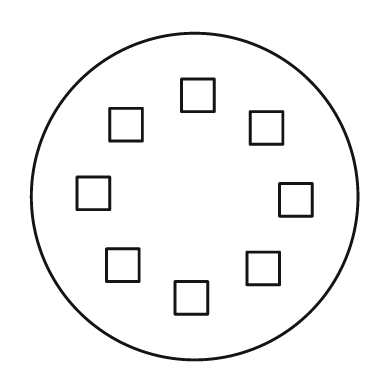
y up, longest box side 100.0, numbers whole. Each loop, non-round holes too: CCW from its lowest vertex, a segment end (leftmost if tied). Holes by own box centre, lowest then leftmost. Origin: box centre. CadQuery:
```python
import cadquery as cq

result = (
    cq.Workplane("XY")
    .moveTo(0.0, 0.0)
    .circle(50.0)
    .moveTo(-6.0, -36.0)
    .lineTo(4.0, -36.0)
    .lineTo(4.0, -26.0)
    .lineTo(-6.0, -26.0)
    .close()
    .moveTo(16.0, -27.0)
    .lineTo(26.0, -27.0)
    .lineTo(26.0, -17.0)
    .lineTo(16.0, -17.0)
    .close()
    .moveTo(-27.0, -26.0)
    .lineTo(-17.0, -26.0)
    .lineTo(-17.0, -16.0)
    .lineTo(-27.0, -16.0)
    .close()
    .moveTo(26.0, -6.0)
    .lineTo(36.0, -6.0)
    .lineTo(36.0, 4.0)
    .lineTo(26.0, 4.0)
    .close()
    .moveTo(-36.0, -4.0)
    .lineTo(-26.0, -4.0)
    .lineTo(-26.0, 6.0)
    .lineTo(-36.0, 6.0)
    .close()
    .moveTo(17.0, 16.0)
    .lineTo(27.0, 16.0)
    .lineTo(27.0, 26.0)
    .lineTo(17.0, 26.0)
    .close()
    .moveTo(-26.0, 17.0)
    .lineTo(-16.0, 17.0)
    .lineTo(-16.0, 27.0)
    .lineTo(-26.0, 27.0)
    .close()
    .moveTo(-4.0, 26.0)
    .lineTo(6.0, 26.0)
    .lineTo(6.0, 36.0)
    .lineTo(-4.0, 36.0)
    .close()
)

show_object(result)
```